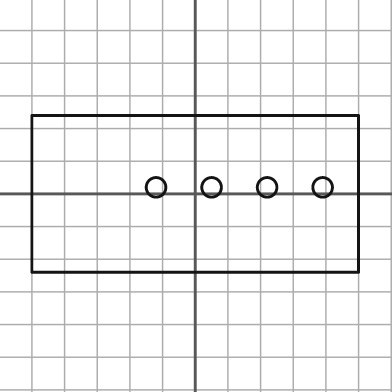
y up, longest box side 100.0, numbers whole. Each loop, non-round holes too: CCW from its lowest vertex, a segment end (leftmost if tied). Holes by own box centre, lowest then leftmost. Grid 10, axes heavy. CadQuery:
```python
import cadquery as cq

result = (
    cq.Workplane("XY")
    .moveTo(-50.0, -24.0)
    .lineTo(50.0, -24.0)
    .lineTo(50.0, 24.0)
    .lineTo(-50.0, 24.0)
    .close()
    .moveTo(-12.0, 2.0)
    .circle(3.0)
    .moveTo(5.0, 2.0)
    .circle(3.0)
    .moveTo(22.0, 2.0)
    .circle(3.0)
    .moveTo(39.0, 2.0)
    .circle(3.0)
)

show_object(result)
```